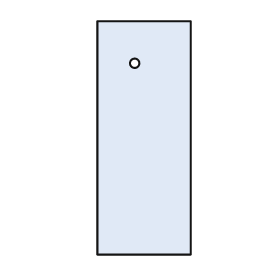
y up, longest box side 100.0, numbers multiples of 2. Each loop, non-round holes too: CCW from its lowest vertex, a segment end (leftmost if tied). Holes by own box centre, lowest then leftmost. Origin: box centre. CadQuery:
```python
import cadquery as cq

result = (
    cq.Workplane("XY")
    .moveTo(-20.0, -50.0)
    .lineTo(20.0, -50.0)
    .lineTo(20.0, 50.0)
    .lineTo(-20.0, 50.0)
    .close()
    .moveTo(-4.0, 32.0)
    .circle(2.0)
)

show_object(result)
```